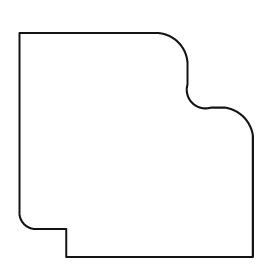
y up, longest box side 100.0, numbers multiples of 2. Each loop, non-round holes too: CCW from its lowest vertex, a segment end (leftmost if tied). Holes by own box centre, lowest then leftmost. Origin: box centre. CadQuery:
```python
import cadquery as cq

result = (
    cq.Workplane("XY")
    .moveTo(-30.0, -48.0)
    .lineTo(50.0, -48.0)
    .lineTo(50.0, 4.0)
    .threePointArc((46.0, 12.0), (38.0, 16.0))
    .lineTo(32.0, 16.0)
    .threePointArc((24.0, 18.0), (22.0, 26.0))
    .lineTo(22.0, 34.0)
    .threePointArc((18.0, 44.0), (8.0, 48.0))
    .lineTo(-50.0, 48.0)
    .lineTo(-50.0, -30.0)
    .threePointArc((-48.0, -34.0), (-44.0, -36.0))
    .lineTo(-30.0, -36.0)
    .close()
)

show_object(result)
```